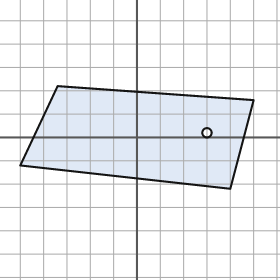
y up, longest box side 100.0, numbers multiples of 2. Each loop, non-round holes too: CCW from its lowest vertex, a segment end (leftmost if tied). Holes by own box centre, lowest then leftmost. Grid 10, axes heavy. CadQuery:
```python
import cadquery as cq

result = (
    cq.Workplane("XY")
    .moveTo(40.0, -22.0)
    .lineTo(50.0, 16.0)
    .lineTo(-34.0, 22.0)
    .lineTo(-50.0, -12.0)
    .close()
    .moveTo(30.0, 2.0)
    .circle(2.0)
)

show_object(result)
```